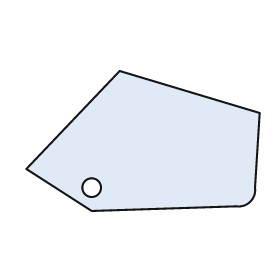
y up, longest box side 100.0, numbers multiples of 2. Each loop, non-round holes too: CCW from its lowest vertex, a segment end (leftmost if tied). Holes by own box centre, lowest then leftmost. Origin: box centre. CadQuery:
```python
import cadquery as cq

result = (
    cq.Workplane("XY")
    .moveTo(-22.0, -30.0)
    .lineTo(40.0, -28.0)
    .threePointArc((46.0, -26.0), (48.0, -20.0))
    .lineTo(50.0, 12.0)
    .lineTo(-10.0, 30.0)
    .lineTo(-50.0, -12.0)
    .close()
    .moveTo(-22.0, -20.0)
    .circle(4.0)
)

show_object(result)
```